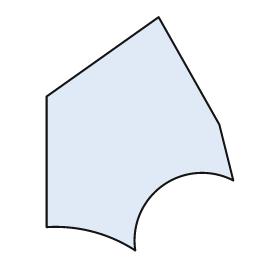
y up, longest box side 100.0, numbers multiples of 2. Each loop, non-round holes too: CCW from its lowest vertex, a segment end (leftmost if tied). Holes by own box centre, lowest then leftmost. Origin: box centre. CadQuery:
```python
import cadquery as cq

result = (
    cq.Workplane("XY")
    .moveTo(-2.0, -50.0)
    .threePointArc((10.0, -22.0), (40.0, -20.0))
    .lineTo(34.0, 4.0)
    .lineTo(8.0, 50.0)
    .lineTo(-40.0, 16.0)
    .lineTo(-40.0, -40.0)
    .threePointArc((-20.0, -42.0), (-2.0, -50.0))
    .close()
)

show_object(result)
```